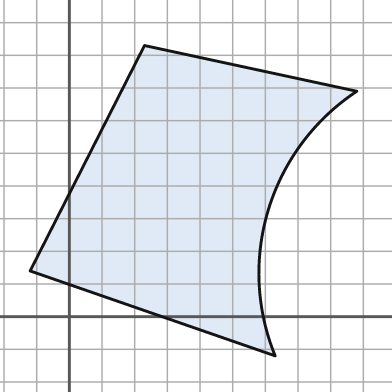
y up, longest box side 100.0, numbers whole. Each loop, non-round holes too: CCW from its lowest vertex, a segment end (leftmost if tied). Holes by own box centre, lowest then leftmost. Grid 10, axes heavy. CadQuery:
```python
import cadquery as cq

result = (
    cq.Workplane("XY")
    .moveTo(63.0, -12.0)
    .threePointArc((61.0, 33.0), (88.0, 69.0))
    .lineTo(23.0, 83.0)
    .lineTo(-12.0, 14.0)
    .close()
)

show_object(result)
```